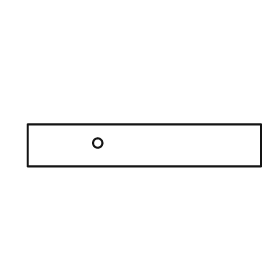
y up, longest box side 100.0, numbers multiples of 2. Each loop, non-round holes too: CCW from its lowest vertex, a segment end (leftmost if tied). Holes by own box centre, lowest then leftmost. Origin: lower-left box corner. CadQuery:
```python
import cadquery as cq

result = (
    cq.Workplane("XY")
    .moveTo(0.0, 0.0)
    .lineTo(100.0, 0.0)
    .lineTo(100.0, 18.0)
    .lineTo(0.0, 18.0)
    .close()
    .moveTo(30.0, 10.0)
    .circle(2.0)
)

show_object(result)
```